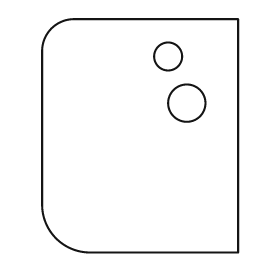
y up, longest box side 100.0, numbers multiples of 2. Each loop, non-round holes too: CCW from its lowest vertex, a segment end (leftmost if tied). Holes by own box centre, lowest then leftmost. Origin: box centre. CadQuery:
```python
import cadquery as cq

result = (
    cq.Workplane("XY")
    .moveTo(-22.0, -50.0)
    .lineTo(42.0, -50.0)
    .lineTo(42.0, 50.0)
    .lineTo(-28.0, 50.0)
    .threePointArc((-38.0, 46.0), (-42.0, 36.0))
    .lineTo(-42.0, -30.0)
    .threePointArc((-36.0, -44.0), (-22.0, -50.0))
    .close()
    .moveTo(20.0, 14.0)
    .circle(8.0)
    .moveTo(12.0, 34.0)
    .circle(6.0)
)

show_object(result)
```